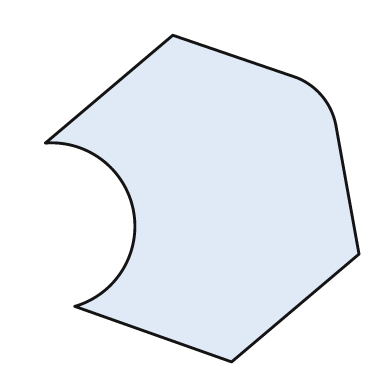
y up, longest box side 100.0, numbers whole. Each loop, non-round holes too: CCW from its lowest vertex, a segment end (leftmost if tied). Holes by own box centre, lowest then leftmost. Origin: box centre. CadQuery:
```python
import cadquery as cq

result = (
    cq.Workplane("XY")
    .moveTo(9.0, -50.0)
    .lineTo(48.0, -17.0)
    .lineTo(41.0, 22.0)
    .threePointArc((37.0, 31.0), (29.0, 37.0))
    .lineTo(-9.0, 50.0)
    .lineTo(-48.0, 17.0)
    .threePointArc((-21.0, -4.0), (-39.0, -33.0))
    .close()
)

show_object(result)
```